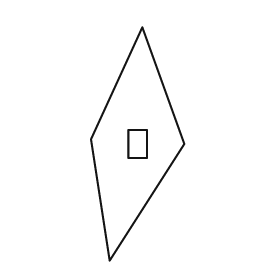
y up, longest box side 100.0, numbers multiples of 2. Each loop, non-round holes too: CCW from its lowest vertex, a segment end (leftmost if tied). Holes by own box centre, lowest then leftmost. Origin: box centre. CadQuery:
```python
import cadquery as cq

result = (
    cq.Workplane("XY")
    .moveTo(-12.0, -50.0)
    .lineTo(20.0, 0.0)
    .lineTo(2.0, 50.0)
    .lineTo(-20.0, 2.0)
    .close()
    .moveTo(-4.0, -6.0)
    .lineTo(4.0, -6.0)
    .lineTo(4.0, 6.0)
    .lineTo(-4.0, 6.0)
    .close()
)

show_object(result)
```